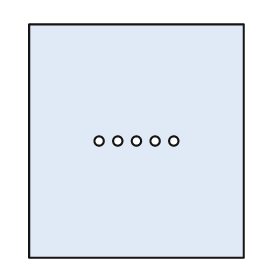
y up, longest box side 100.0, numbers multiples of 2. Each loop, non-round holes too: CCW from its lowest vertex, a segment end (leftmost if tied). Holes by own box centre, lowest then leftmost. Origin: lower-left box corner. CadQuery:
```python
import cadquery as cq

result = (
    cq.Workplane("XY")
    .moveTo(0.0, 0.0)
    .lineTo(92.0, 0.0)
    .lineTo(92.0, 100.0)
    .lineTo(0.0, 100.0)
    .close()
    .moveTo(30.0, 50.0)
    .circle(2.0)
    .moveTo(38.0, 50.0)
    .circle(2.0)
    .moveTo(46.0, 50.0)
    .circle(2.0)
    .moveTo(54.0, 50.0)
    .circle(2.0)
    .moveTo(62.0, 50.0)
    .circle(2.0)
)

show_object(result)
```